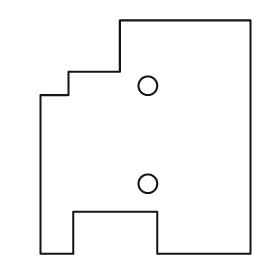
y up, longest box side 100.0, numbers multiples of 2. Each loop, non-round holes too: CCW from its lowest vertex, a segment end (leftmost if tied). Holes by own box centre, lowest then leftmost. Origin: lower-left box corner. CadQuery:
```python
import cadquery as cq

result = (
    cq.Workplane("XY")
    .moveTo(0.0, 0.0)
    .lineTo(14.0, 0.0)
    .lineTo(14.0, 18.0)
    .lineTo(50.0, 18.0)
    .lineTo(50.0, 0.0)
    .lineTo(90.0, 0.0)
    .lineTo(90.0, 100.0)
    .lineTo(34.0, 100.0)
    .lineTo(34.0, 78.0)
    .lineTo(12.0, 78.0)
    .lineTo(12.0, 68.0)
    .lineTo(0.0, 68.0)
    .close()
    .moveTo(46.0, 30.0)
    .circle(4.0)
    .moveTo(46.0, 72.0)
    .circle(4.0)
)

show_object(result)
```